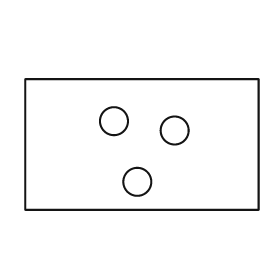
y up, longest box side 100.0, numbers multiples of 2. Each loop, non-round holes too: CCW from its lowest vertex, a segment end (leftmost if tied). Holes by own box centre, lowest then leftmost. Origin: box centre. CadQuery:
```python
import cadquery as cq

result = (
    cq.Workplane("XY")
    .moveTo(-50.0, -28.0)
    .lineTo(50.0, -28.0)
    .lineTo(50.0, 28.0)
    .lineTo(-50.0, 28.0)
    .close()
    .moveTo(-2.0, -16.0)
    .circle(6.0)
    .moveTo(14.0, 6.0)
    .circle(6.0)
    .moveTo(-12.0, 10.0)
    .circle(6.0)
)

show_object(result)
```